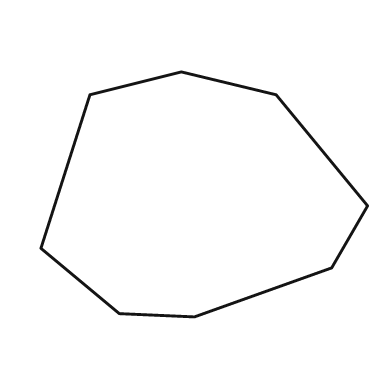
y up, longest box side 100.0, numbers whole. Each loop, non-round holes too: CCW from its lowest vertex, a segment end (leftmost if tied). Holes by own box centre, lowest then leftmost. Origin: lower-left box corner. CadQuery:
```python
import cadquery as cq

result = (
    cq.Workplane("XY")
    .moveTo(47.0, 0.0)
    .lineTo(89.0, 15.0)
    .lineTo(100.0, 34.0)
    .lineTo(72.0, 68.0)
    .lineTo(43.0, 75.0)
    .lineTo(15.0, 68.0)
    .lineTo(0.0, 21.0)
    .lineTo(24.0, 1.0)
    .close()
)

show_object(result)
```